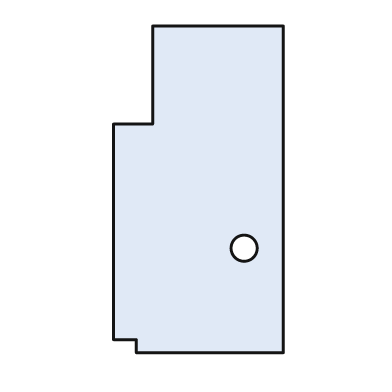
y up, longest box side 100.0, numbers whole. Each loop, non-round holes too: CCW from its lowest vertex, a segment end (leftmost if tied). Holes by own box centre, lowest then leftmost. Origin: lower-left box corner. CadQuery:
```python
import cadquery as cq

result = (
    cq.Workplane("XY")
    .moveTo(7.0, 0.0)
    .lineTo(52.0, 0.0)
    .lineTo(52.0, 100.0)
    .lineTo(12.0, 100.0)
    .lineTo(12.0, 70.0)
    .lineTo(0.0, 70.0)
    .lineTo(0.0, 4.0)
    .lineTo(7.0, 4.0)
    .close()
    .moveTo(40.0, 32.0)
    .circle(4.0)
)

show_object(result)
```